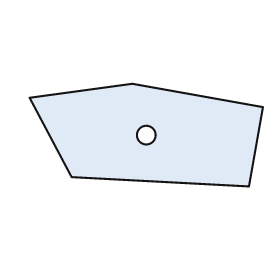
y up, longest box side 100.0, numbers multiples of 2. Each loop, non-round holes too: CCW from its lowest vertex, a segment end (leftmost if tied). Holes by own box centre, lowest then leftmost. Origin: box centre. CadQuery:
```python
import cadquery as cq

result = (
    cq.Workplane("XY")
    .moveTo(44.0, -22.0)
    .lineTo(50.0, 12.0)
    .lineTo(-6.0, 22.0)
    .lineTo(-50.0, 16.0)
    .lineTo(-32.0, -18.0)
    .close()
    .moveTo(0.0, 0.0)
    .circle(4.0)
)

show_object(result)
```